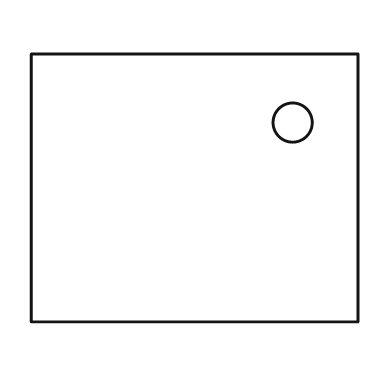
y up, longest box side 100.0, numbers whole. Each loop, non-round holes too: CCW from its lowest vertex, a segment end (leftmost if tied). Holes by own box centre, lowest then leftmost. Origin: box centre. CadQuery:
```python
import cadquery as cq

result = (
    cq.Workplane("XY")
    .moveTo(-50.0, -41.0)
    .lineTo(50.0, -41.0)
    .lineTo(50.0, 41.0)
    .lineTo(-50.0, 41.0)
    .close()
    .moveTo(30.0, 20.0)
    .circle(6.0)
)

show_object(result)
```